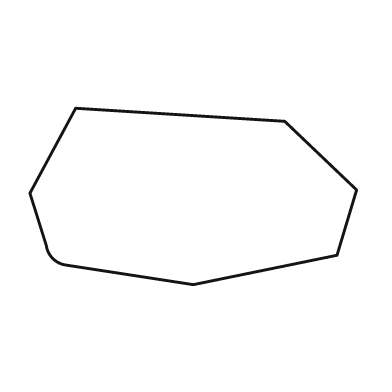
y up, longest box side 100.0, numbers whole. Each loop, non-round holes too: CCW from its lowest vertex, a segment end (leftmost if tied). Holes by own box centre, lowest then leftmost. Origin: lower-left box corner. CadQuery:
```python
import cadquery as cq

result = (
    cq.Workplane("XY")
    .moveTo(50.0, 0.0)
    .lineTo(94.0, 9.0)
    .lineTo(100.0, 29.0)
    .lineTo(78.0, 50.0)
    .lineTo(14.0, 54.0)
    .lineTo(0.0, 28.0)
    .lineTo(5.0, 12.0)
    .threePointArc((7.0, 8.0), (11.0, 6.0))
    .close()
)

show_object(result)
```